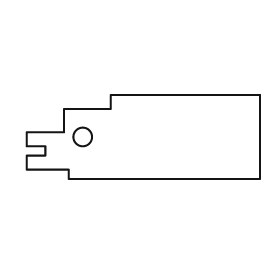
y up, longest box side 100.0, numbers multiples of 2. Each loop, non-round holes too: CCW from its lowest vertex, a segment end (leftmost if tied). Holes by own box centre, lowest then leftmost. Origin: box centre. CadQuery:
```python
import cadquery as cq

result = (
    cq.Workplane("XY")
    .moveTo(-32.0, -18.0)
    .lineTo(50.0, -18.0)
    .lineTo(50.0, 18.0)
    .lineTo(-14.0, 18.0)
    .lineTo(-14.0, 12.0)
    .lineTo(-34.0, 12.0)
    .lineTo(-34.0, 2.0)
    .lineTo(-50.0, 2.0)
    .lineTo(-50.0, -4.0)
    .lineTo(-42.0, -4.0)
    .lineTo(-42.0, -8.0)
    .lineTo(-50.0, -8.0)
    .lineTo(-50.0, -14.0)
    .lineTo(-32.0, -14.0)
    .close()
    .moveTo(-26.0, 0.0)
    .circle(4.0)
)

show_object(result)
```